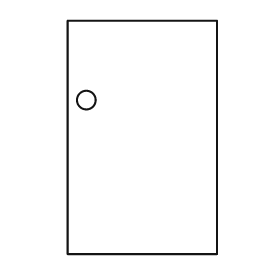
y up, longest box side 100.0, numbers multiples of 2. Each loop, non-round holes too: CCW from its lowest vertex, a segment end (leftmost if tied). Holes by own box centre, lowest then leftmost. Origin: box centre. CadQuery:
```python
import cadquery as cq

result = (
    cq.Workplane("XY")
    .moveTo(-32.0, -50.0)
    .lineTo(32.0, -50.0)
    .lineTo(32.0, 50.0)
    .lineTo(-32.0, 50.0)
    .close()
    .moveTo(-24.0, 16.0)
    .circle(4.0)
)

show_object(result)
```